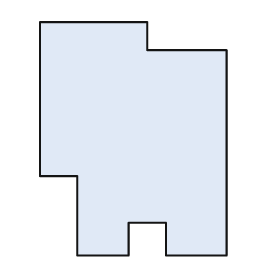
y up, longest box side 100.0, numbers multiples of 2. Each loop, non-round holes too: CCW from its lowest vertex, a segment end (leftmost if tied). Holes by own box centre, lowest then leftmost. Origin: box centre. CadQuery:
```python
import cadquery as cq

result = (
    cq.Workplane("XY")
    .moveTo(-24.0, -50.0)
    .lineTo(-2.0, -50.0)
    .lineTo(-2.0, -36.0)
    .lineTo(14.0, -36.0)
    .lineTo(14.0, -50.0)
    .lineTo(40.0, -50.0)
    .lineTo(40.0, 38.0)
    .lineTo(6.0, 38.0)
    .lineTo(6.0, 50.0)
    .lineTo(-40.0, 50.0)
    .lineTo(-40.0, -16.0)
    .lineTo(-24.0, -16.0)
    .close()
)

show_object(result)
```